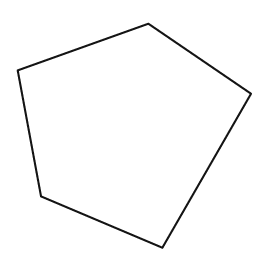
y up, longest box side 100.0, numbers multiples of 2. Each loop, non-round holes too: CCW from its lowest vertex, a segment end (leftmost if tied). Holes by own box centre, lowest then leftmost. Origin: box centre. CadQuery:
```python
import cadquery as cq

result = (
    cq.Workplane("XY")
    .moveTo(12.0, -48.0)
    .lineTo(50.0, 18.0)
    .lineTo(6.0, 48.0)
    .lineTo(-50.0, 28.0)
    .lineTo(-40.0, -26.0)
    .close()
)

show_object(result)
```